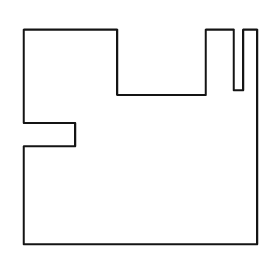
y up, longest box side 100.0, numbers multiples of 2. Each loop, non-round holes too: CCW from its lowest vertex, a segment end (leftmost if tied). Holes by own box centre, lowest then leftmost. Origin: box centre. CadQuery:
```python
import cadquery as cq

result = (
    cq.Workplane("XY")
    .moveTo(-50.0, -46.0)
    .lineTo(50.0, -46.0)
    .lineTo(50.0, 46.0)
    .lineTo(44.0, 46.0)
    .lineTo(44.0, 20.0)
    .lineTo(40.0, 20.0)
    .lineTo(40.0, 46.0)
    .lineTo(28.0, 46.0)
    .lineTo(28.0, 18.0)
    .lineTo(-10.0, 18.0)
    .lineTo(-10.0, 46.0)
    .lineTo(-50.0, 46.0)
    .lineTo(-50.0, 6.0)
    .lineTo(-28.0, 6.0)
    .lineTo(-28.0, -4.0)
    .lineTo(-50.0, -4.0)
    .close()
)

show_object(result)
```